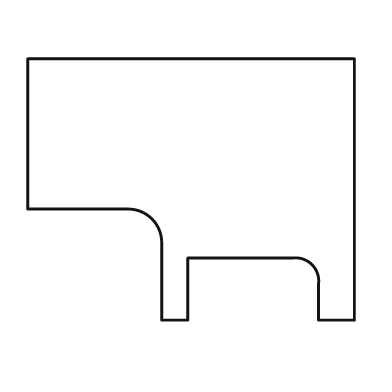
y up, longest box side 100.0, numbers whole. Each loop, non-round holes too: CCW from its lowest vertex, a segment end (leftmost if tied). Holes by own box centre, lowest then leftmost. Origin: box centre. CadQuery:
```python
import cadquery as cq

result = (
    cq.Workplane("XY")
    .moveTo(-9.0, -40.0)
    .lineTo(-1.0, -40.0)
    .lineTo(-1.0, -21.0)
    .lineTo(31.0, -21.0)
    .threePointArc((37.0, -23.0), (39.0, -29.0))
    .lineTo(39.0, -40.0)
    .lineTo(50.0, -40.0)
    .lineTo(50.0, 40.0)
    .lineTo(-50.0, 40.0)
    .lineTo(-50.0, -6.0)
    .lineTo(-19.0, -6.0)
    .threePointArc((-12.0, -9.0), (-9.0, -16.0))
    .close()
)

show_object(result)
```